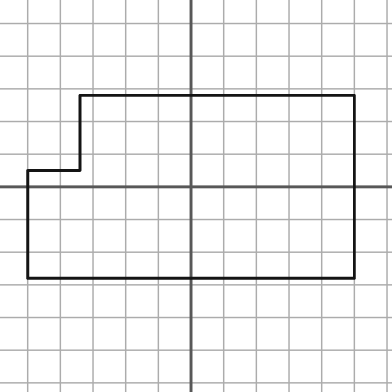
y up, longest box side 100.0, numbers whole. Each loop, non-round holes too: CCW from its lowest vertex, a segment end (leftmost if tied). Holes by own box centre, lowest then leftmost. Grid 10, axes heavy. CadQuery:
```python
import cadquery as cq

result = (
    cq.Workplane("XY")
    .moveTo(-50.0, -28.0)
    .lineTo(50.0, -28.0)
    .lineTo(50.0, 28.0)
    .lineTo(-34.0, 28.0)
    .lineTo(-34.0, 5.0)
    .lineTo(-50.0, 5.0)
    .close()
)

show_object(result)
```